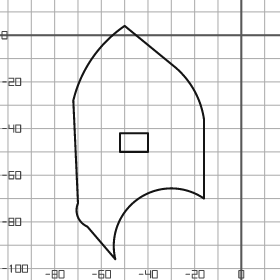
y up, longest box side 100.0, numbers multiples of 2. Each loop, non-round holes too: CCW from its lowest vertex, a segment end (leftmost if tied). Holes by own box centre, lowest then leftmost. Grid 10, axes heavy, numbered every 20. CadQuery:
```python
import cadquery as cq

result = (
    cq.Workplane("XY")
    .moveTo(-54.0, -96.0)
    .threePointArc((-44.0, -70.0), (-16.0, -70.0))
    .lineTo(-16.0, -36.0)
    .threePointArc((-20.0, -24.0), (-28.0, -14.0))
    .lineTo(-50.0, 4.0)
    .threePointArc((-64.0, -10.0), (-72.0, -28.0))
    .lineTo(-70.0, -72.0)
    .threePointArc((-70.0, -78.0), (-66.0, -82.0))
    .close()
    .moveTo(-52.0, -50.0)
    .lineTo(-40.0, -50.0)
    .lineTo(-40.0, -42.0)
    .lineTo(-52.0, -42.0)
    .close()
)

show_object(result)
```